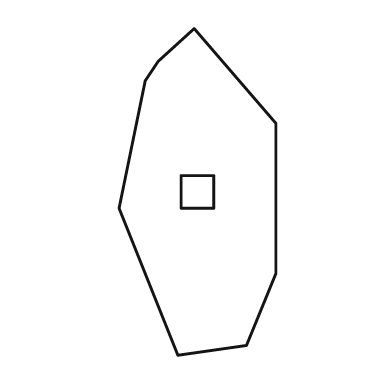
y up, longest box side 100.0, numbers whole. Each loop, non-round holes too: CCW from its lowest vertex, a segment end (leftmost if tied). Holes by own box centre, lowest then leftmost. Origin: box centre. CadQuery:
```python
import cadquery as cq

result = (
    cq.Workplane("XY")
    .moveTo(-6.0, -50.0)
    .lineTo(15.0, -47.0)
    .lineTo(24.0, -25.0)
    .lineTo(24.0, 21.0)
    .lineTo(-1.0, 50.0)
    .lineTo(-12.0, 40.0)
    .lineTo(-16.0, 34.0)
    .lineTo(-24.0, -5.0)
    .close()
    .moveTo(-5.0, -5.0)
    .lineTo(5.0, -5.0)
    .lineTo(5.0, 5.0)
    .lineTo(-5.0, 5.0)
    .close()
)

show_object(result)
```